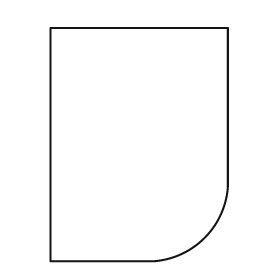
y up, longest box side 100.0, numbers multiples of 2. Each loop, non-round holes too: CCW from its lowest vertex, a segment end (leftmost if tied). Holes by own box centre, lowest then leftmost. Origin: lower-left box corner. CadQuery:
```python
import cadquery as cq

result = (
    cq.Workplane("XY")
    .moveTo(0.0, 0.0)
    .lineTo(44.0, 0.0)
    .threePointArc((66.0, 10.0), (76.0, 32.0))
    .lineTo(76.0, 100.0)
    .lineTo(0.0, 100.0)
    .close()
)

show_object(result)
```